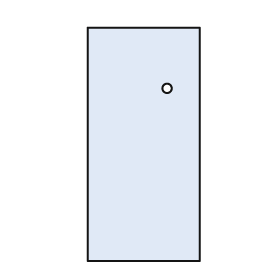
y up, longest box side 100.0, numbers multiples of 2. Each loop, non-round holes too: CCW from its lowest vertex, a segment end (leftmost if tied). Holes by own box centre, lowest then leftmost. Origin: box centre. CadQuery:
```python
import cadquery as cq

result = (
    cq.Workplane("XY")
    .moveTo(-24.0, -50.0)
    .lineTo(24.0, -50.0)
    .lineTo(24.0, 50.0)
    .lineTo(-24.0, 50.0)
    .close()
    .moveTo(10.0, 24.0)
    .circle(2.0)
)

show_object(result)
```